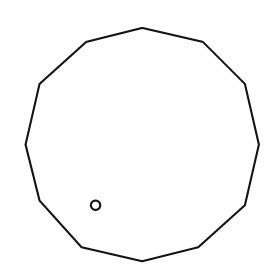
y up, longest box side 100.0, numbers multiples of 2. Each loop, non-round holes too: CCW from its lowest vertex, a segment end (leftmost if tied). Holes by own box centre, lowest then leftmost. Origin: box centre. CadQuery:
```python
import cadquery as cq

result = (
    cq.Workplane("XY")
    .moveTo(0.0, -50.0)
    .lineTo(24.0, -44.0)
    .lineTo(44.0, -26.0)
    .lineTo(50.0, 0.0)
    .lineTo(44.0, 26.0)
    .lineTo(26.0, 44.0)
    .lineTo(0.0, 50.0)
    .lineTo(-24.0, 44.0)
    .lineTo(-44.0, 26.0)
    .lineTo(-50.0, 0.0)
    .lineTo(-44.0, -24.0)
    .lineTo(-26.0, -44.0)
    .close()
    .moveTo(-20.0, -26.0)
    .circle(2.0)
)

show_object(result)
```